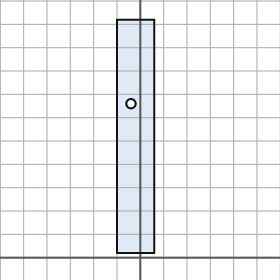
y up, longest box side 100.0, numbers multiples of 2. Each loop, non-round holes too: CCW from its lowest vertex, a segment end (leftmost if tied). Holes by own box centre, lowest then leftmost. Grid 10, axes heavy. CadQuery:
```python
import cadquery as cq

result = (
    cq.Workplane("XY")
    .moveTo(-10.0, 2.0)
    .lineTo(6.0, 2.0)
    .lineTo(6.0, 102.0)
    .lineTo(-10.0, 102.0)
    .close()
    .moveTo(-4.0, 66.0)
    .circle(2.0)
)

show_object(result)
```